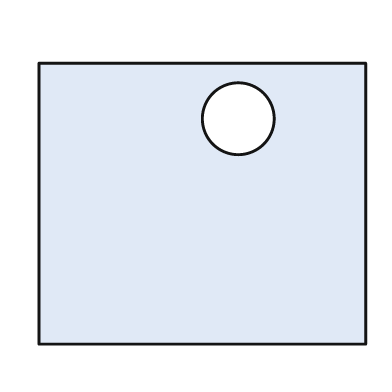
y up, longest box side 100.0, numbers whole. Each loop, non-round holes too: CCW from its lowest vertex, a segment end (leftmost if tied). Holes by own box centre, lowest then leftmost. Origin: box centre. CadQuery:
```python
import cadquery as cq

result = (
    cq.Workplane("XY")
    .moveTo(-50.0, -43.0)
    .lineTo(50.0, -43.0)
    .lineTo(50.0, 43.0)
    .lineTo(-50.0, 43.0)
    .close()
    .moveTo(11.0, 26.0)
    .circle(11.0)
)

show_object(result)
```